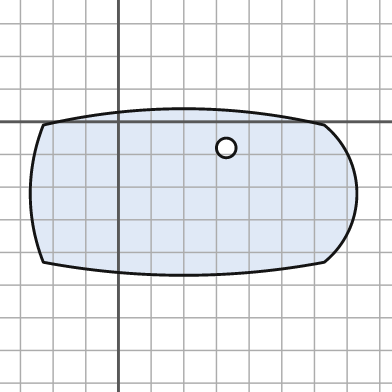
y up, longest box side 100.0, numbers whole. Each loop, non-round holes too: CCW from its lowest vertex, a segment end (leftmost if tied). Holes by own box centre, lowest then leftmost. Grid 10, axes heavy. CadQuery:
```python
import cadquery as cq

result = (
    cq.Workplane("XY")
    .moveTo(-23.0, -43.0)
    .threePointArc((20.0, -47.0), (63.0, -43.0))
    .threePointArc((73.0, -22.0), (63.0, -1.0))
    .threePointArc((20.0, 4.0), (-23.0, -1.0))
    .threePointArc((-27.0, -22.0), (-23.0, -43.0))
    .close()
    .moveTo(33.0, -8.0)
    .circle(3.0)
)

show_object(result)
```